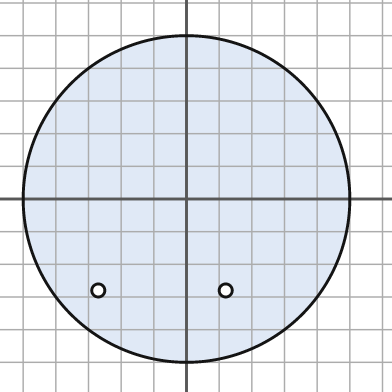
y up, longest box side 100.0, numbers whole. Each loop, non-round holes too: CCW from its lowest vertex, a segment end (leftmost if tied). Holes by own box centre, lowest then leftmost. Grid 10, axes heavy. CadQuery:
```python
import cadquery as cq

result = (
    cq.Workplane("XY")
    .moveTo(0.0, 0.0)
    .circle(50.0)
    .moveTo(-27.0, -28.0)
    .circle(2.0)
    .moveTo(12.0, -28.0)
    .circle(2.0)
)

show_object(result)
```